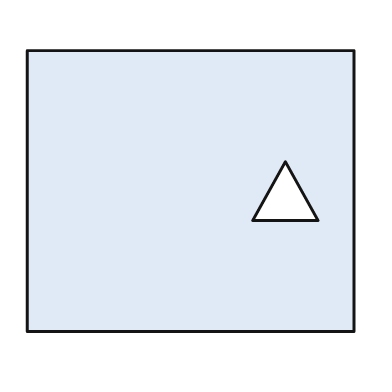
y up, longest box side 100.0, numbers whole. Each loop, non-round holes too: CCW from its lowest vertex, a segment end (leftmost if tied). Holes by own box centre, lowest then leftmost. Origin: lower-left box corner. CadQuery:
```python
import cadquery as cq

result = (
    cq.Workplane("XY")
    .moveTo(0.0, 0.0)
    .lineTo(100.0, 0.0)
    .lineTo(100.0, 86.0)
    .lineTo(0.0, 86.0)
    .close()
    .moveTo(69.0, 34.0)
    .lineTo(89.0, 34.0)
    .lineTo(79.0, 52.0)
    .close()
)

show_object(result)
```